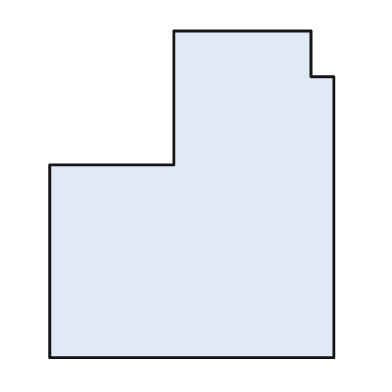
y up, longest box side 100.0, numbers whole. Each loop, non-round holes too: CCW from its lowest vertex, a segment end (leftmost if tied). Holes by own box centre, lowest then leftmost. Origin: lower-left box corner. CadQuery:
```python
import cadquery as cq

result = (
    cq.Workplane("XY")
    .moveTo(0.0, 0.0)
    .lineTo(87.0, 0.0)
    .lineTo(87.0, 86.0)
    .lineTo(80.0, 86.0)
    .lineTo(80.0, 100.0)
    .lineTo(38.0, 100.0)
    .lineTo(38.0, 59.0)
    .lineTo(0.0, 59.0)
    .close()
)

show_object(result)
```